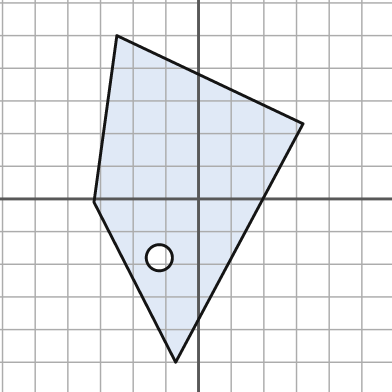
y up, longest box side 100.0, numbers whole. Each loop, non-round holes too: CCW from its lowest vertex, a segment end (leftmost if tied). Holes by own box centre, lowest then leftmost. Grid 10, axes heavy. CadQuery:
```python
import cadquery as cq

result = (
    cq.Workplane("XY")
    .moveTo(-7.0, -50.0)
    .lineTo(32.0, 23.0)
    .lineTo(-25.0, 50.0)
    .lineTo(-32.0, -1.0)
    .close()
    .moveTo(-12.0, -18.0)
    .circle(4.0)
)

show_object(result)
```